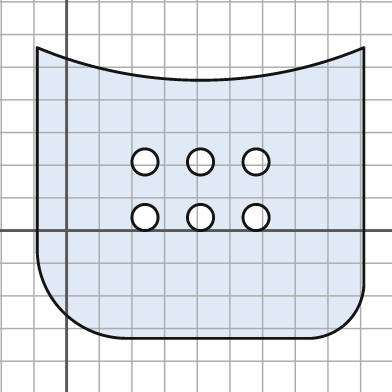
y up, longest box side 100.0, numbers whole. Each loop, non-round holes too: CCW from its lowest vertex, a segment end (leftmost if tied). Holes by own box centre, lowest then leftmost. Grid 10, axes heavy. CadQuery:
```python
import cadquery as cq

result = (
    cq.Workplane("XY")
    .moveTo(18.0, -33.0)
    .lineTo(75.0, -33.0)
    .threePointArc((86.0, -28.0), (91.0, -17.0))
    .lineTo(91.0, 56.0)
    .threePointArc((41.0, 46.0), (-9.0, 56.0))
    .lineTo(-9.0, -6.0)
    .threePointArc((-1.0, -25.0), (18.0, -33.0))
    .close()
    .moveTo(24.0, 4.0)
    .circle(4.0)
    .moveTo(41.0, 4.0)
    .circle(4.0)
    .moveTo(58.0, 4.0)
    .circle(4.0)
    .moveTo(24.0, 21.0)
    .circle(4.0)
    .moveTo(41.0, 21.0)
    .circle(4.0)
    .moveTo(58.0, 21.0)
    .circle(4.0)
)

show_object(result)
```